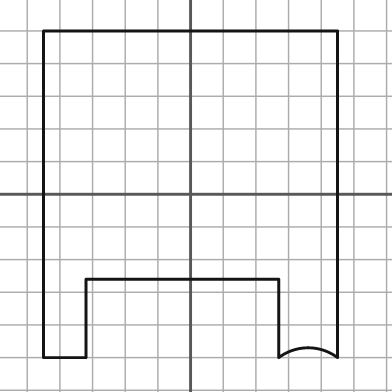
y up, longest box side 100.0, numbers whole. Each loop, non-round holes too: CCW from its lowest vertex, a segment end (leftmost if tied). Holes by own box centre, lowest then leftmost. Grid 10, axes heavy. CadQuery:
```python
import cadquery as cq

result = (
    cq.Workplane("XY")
    .moveTo(-45.0, -50.0)
    .lineTo(-32.0, -50.0)
    .lineTo(-32.0, -26.0)
    .lineTo(27.0, -26.0)
    .lineTo(27.0, -50.0)
    .threePointArc((36.0, -47.0), (45.0, -50.0))
    .lineTo(45.0, 50.0)
    .lineTo(-45.0, 50.0)
    .close()
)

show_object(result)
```